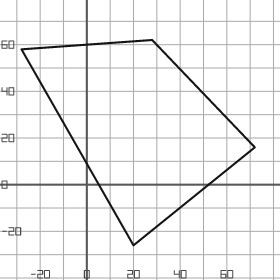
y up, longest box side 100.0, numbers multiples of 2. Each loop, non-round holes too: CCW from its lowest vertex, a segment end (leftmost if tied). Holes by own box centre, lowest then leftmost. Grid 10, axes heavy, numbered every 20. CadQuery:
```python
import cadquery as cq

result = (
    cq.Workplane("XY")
    .moveTo(20.0, -26.0)
    .lineTo(72.0, 16.0)
    .lineTo(28.0, 62.0)
    .lineTo(-28.0, 58.0)
    .close()
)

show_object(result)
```